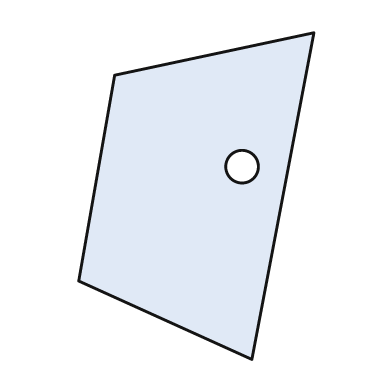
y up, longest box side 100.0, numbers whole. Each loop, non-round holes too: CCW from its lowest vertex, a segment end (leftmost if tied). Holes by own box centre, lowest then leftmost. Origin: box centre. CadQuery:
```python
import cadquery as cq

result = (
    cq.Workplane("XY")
    .moveTo(17.0, -50.0)
    .lineTo(36.0, 50.0)
    .lineTo(-25.0, 37.0)
    .lineTo(-36.0, -26.0)
    .close()
    .moveTo(14.0, 9.0)
    .circle(5.0)
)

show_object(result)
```